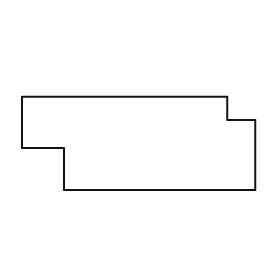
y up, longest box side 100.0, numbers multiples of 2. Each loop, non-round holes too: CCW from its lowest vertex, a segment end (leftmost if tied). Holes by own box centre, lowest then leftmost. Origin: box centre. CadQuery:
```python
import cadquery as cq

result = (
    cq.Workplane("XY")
    .moveTo(-32.0, -20.0)
    .lineTo(50.0, -20.0)
    .lineTo(50.0, 10.0)
    .lineTo(38.0, 10.0)
    .lineTo(38.0, 20.0)
    .lineTo(-50.0, 20.0)
    .lineTo(-50.0, -2.0)
    .lineTo(-32.0, -2.0)
    .close()
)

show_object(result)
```